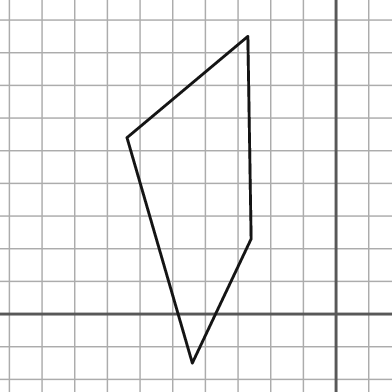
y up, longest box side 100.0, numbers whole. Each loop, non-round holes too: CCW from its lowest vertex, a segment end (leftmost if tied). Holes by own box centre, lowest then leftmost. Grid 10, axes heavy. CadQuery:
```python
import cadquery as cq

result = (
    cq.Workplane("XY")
    .moveTo(-44.0, -15.0)
    .lineTo(-26.0, 23.0)
    .lineTo(-27.0, 85.0)
    .lineTo(-64.0, 54.0)
    .close()
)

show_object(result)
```